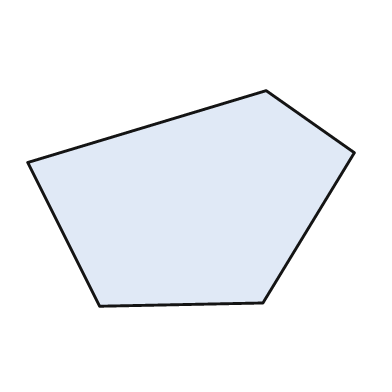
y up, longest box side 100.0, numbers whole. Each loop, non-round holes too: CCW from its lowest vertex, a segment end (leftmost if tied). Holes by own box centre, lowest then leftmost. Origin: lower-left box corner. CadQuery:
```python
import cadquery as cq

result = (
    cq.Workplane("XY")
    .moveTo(22.0, 0.0)
    .lineTo(72.0, 1.0)
    .lineTo(100.0, 47.0)
    .lineTo(73.0, 66.0)
    .lineTo(0.0, 44.0)
    .close()
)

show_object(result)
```